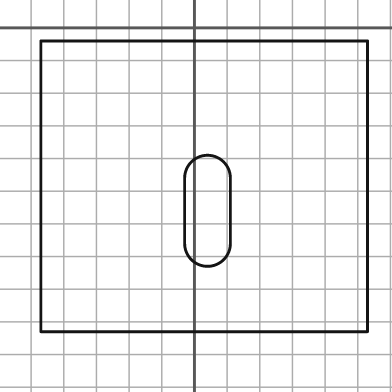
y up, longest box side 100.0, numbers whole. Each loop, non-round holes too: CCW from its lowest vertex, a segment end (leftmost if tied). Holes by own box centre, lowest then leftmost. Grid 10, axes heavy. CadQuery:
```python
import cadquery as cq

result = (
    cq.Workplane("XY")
    .moveTo(-47.0, -93.0)
    .lineTo(53.0, -93.0)
    .lineTo(53.0, -4.0)
    .lineTo(-47.0, -4.0)
    .close()
    .moveTo(-3.0, -66.0)
    .threePointArc((4.0, -73.0), (11.0, -66.0))
    .lineTo(11.0, -46.0)
    .threePointArc((4.0, -39.0), (-3.0, -46.0))
    .close()
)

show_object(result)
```